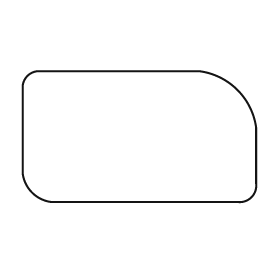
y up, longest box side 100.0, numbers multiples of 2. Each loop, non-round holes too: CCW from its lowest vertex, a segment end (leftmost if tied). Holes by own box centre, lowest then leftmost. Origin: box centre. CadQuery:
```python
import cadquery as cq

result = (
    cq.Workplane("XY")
    .moveTo(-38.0, -28.0)
    .lineTo(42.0, -28.0)
    .threePointArc((48.0, -26.0), (50.0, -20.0))
    .lineTo(50.0, 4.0)
    .threePointArc((42.0, 20.0), (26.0, 28.0))
    .lineTo(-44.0, 28.0)
    .threePointArc((-48.0, 26.0), (-50.0, 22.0))
    .lineTo(-50.0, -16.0)
    .threePointArc((-46.0, -24.0), (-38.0, -28.0))
    .close()
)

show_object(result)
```